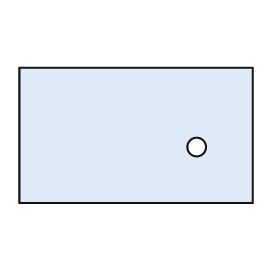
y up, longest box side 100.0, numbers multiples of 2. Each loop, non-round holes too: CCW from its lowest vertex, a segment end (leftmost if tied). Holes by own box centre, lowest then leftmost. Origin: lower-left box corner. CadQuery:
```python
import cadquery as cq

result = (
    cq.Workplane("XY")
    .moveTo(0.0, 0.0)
    .lineTo(100.0, 0.0)
    .lineTo(100.0, 58.0)
    .lineTo(0.0, 58.0)
    .close()
    .moveTo(76.0, 24.0)
    .circle(4.0)
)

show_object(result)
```